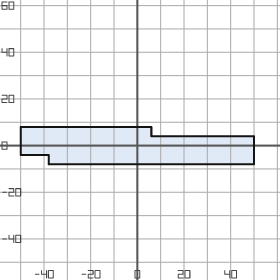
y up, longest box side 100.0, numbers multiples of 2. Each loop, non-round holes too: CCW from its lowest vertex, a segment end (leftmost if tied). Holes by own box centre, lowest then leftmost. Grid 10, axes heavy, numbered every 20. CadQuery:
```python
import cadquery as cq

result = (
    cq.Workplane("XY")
    .moveTo(-38.0, -8.0)
    .lineTo(50.0, -8.0)
    .lineTo(50.0, 4.0)
    .lineTo(6.0, 4.0)
    .lineTo(6.0, 8.0)
    .lineTo(-50.0, 8.0)
    .lineTo(-50.0, -4.0)
    .lineTo(-38.0, -4.0)
    .close()
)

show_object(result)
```